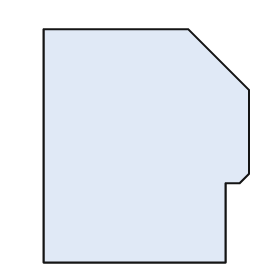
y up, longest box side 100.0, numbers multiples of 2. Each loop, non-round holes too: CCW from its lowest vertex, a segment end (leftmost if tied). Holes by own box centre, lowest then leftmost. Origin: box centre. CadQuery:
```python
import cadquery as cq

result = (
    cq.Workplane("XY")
    .moveTo(-44.0, -50.0)
    .lineTo(34.0, -50.0)
    .lineTo(34.0, -16.0)
    .lineTo(40.0, -16.0)
    .lineTo(44.0, -12.0)
    .lineTo(44.0, 24.0)
    .lineTo(18.0, 50.0)
    .lineTo(-44.0, 50.0)
    .close()
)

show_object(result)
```